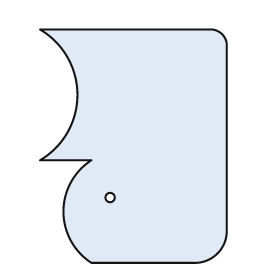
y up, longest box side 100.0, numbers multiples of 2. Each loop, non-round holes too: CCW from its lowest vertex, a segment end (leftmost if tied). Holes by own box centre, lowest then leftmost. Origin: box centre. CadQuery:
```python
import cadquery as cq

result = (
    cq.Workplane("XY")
    .moveTo(-18.0, -50.0)
    .lineTo(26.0, -50.0)
    .threePointArc((36.0, -46.0), (40.0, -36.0))
    .lineTo(40.0, 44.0)
    .threePointArc((38.0, 48.0), (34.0, 50.0))
    .lineTo(-40.0, 50.0)
    .threePointArc((-24.0, 22.0), (-40.0, -6.0))
    .lineTo(-18.0, -6.0)
    .threePointArc((-30.0, -28.0), (-18.0, -50.0))
    .close()
    .moveTo(-10.0, -22.0)
    .circle(2.0)
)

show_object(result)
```